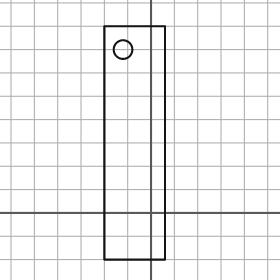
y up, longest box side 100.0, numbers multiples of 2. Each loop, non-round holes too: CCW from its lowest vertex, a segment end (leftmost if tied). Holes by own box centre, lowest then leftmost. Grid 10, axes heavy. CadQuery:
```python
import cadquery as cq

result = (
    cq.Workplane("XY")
    .moveTo(-20.0, -20.0)
    .lineTo(6.0, -20.0)
    .lineTo(6.0, 80.0)
    .lineTo(-20.0, 80.0)
    .close()
    .moveTo(-12.0, 70.0)
    .circle(4.0)
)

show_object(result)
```